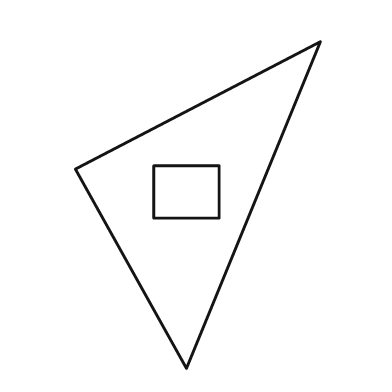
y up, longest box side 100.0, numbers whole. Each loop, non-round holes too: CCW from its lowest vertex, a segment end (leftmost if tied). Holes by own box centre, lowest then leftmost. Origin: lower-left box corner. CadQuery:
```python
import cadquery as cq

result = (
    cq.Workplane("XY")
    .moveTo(34.0, 0.0)
    .lineTo(75.0, 100.0)
    .lineTo(0.0, 61.0)
    .close()
    .moveTo(24.0, 46.0)
    .lineTo(44.0, 46.0)
    .lineTo(44.0, 62.0)
    .lineTo(24.0, 62.0)
    .close()
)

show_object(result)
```